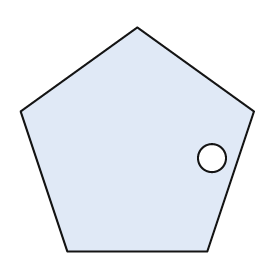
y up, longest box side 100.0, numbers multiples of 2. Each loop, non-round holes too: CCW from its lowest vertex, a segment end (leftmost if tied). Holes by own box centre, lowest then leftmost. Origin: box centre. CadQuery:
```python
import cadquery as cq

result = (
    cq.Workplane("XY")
    .moveTo(-30.0, -48.0)
    .lineTo(30.0, -48.0)
    .lineTo(50.0, 12.0)
    .lineTo(0.0, 48.0)
    .lineTo(-50.0, 12.0)
    .close()
    .moveTo(32.0, -8.0)
    .circle(6.0)
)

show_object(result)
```